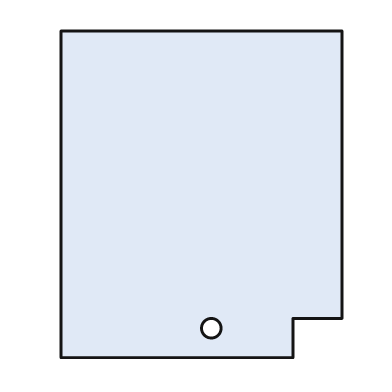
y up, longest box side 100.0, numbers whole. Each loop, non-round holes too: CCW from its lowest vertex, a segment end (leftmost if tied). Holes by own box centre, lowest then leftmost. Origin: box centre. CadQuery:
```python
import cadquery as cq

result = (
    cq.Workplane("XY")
    .moveTo(-43.0, -50.0)
    .lineTo(28.0, -50.0)
    .lineTo(28.0, -38.0)
    .lineTo(43.0, -38.0)
    .lineTo(43.0, 50.0)
    .lineTo(-43.0, 50.0)
    .close()
    .moveTo(3.0, -41.0)
    .circle(3.0)
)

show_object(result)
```